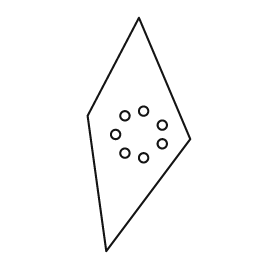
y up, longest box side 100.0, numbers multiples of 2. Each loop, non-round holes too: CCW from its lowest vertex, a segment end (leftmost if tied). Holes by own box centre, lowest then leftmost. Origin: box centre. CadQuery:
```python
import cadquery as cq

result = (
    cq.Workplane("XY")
    .moveTo(-14.0, -50.0)
    .lineTo(22.0, -2.0)
    .lineTo(0.0, 50.0)
    .lineTo(-22.0, 8.0)
    .close()
    .moveTo(2.0, -10.0)
    .circle(2.0)
    .moveTo(-6.0, -8.0)
    .circle(2.0)
    .moveTo(10.0, -4.0)
    .circle(2.0)
    .moveTo(-10.0, 0.0)
    .circle(2.0)
    .moveTo(10.0, 4.0)
    .circle(2.0)
    .moveTo(-6.0, 8.0)
    .circle(2.0)
    .moveTo(2.0, 10.0)
    .circle(2.0)
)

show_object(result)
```